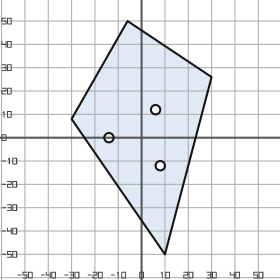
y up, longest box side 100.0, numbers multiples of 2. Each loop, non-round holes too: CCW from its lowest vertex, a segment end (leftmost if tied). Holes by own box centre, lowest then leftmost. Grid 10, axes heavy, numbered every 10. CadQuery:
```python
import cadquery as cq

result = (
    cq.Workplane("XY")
    .moveTo(10.0, -50.0)
    .lineTo(30.0, 26.0)
    .lineTo(-6.0, 50.0)
    .lineTo(-30.0, 8.0)
    .close()
    .moveTo(8.0, -12.0)
    .circle(2.0)
    .moveTo(-14.0, 0.0)
    .circle(2.0)
    .moveTo(6.0, 12.0)
    .circle(2.0)
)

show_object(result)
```